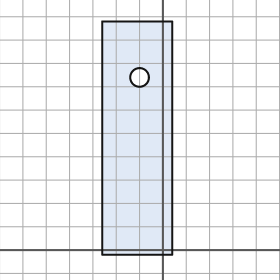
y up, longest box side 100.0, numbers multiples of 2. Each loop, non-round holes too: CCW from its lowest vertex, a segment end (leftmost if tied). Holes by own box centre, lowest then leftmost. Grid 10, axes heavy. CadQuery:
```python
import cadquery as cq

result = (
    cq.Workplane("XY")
    .moveTo(-26.0, -2.0)
    .lineTo(4.0, -2.0)
    .lineTo(4.0, 98.0)
    .lineTo(-26.0, 98.0)
    .close()
    .moveTo(-10.0, 74.0)
    .circle(4.0)
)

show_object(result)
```